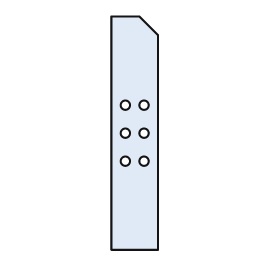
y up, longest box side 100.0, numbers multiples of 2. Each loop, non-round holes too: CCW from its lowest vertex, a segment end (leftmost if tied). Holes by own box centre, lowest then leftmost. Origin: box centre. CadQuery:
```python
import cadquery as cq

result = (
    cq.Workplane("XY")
    .moveTo(-10.0, -50.0)
    .lineTo(10.0, -50.0)
    .lineTo(10.0, 42.0)
    .lineTo(2.0, 50.0)
    .lineTo(-10.0, 50.0)
    .close()
    .moveTo(-4.0, -12.0)
    .circle(2.0)
    .moveTo(4.0, -12.0)
    .circle(2.0)
    .moveTo(-4.0, 0.0)
    .circle(2.0)
    .moveTo(4.0, 0.0)
    .circle(2.0)
    .moveTo(-4.0, 12.0)
    .circle(2.0)
    .moveTo(4.0, 12.0)
    .circle(2.0)
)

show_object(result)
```